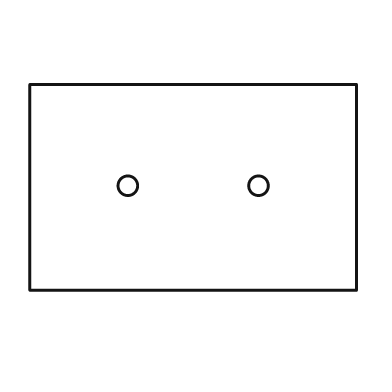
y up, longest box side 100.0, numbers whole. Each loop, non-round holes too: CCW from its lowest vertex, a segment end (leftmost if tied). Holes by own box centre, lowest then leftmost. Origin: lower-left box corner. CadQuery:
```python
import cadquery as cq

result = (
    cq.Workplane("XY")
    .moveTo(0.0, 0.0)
    .lineTo(100.0, 0.0)
    .lineTo(100.0, 63.0)
    .lineTo(0.0, 63.0)
    .close()
    .moveTo(30.0, 32.0)
    .circle(3.0)
    .moveTo(70.0, 32.0)
    .circle(3.0)
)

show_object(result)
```